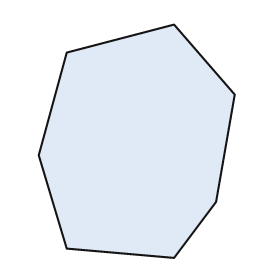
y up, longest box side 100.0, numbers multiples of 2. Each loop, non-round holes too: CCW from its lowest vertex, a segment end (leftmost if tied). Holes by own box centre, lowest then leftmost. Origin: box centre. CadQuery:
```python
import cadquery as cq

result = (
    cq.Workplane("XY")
    .moveTo(16.0, -50.0)
    .lineTo(34.0, -26.0)
    .lineTo(42.0, 20.0)
    .lineTo(16.0, 50.0)
    .lineTo(-30.0, 38.0)
    .lineTo(-42.0, -6.0)
    .lineTo(-30.0, -46.0)
    .close()
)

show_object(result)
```